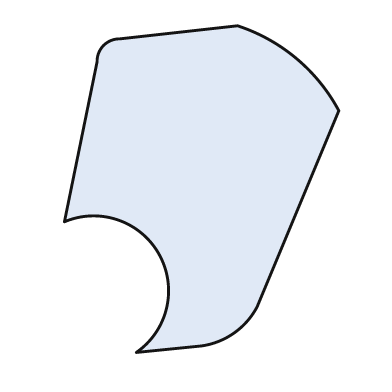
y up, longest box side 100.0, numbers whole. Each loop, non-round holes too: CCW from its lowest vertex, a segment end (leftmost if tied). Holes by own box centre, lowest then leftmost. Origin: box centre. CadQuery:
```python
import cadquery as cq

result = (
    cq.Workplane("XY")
    .moveTo(-20.0, -50.0)
    .lineTo(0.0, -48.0)
    .threePointArc((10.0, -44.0), (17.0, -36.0))
    .lineTo(42.0, 24.0)
    .threePointArc((29.0, 40.0), (11.0, 50.0))
    .lineTo(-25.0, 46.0)
    .threePointArc((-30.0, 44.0), (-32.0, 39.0))
    .lineTo(-42.0, -10.0)
    .threePointArc((-13.0, -20.0), (-20.0, -50.0))
    .close()
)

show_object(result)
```